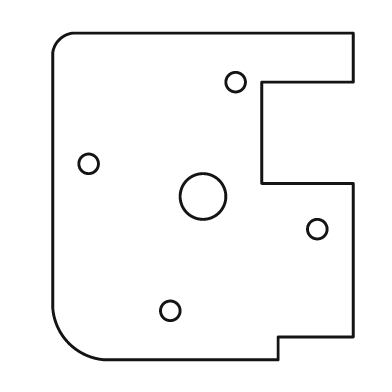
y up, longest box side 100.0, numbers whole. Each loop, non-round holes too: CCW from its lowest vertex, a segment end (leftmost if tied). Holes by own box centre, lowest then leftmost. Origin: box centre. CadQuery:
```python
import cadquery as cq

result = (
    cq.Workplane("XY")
    .moveTo(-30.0, -50.0)
    .lineTo(23.0, -50.0)
    .lineTo(23.0, -43.0)
    .lineTo(46.0, -43.0)
    .lineTo(46.0, 4.0)
    .lineTo(18.0, 4.0)
    .lineTo(18.0, 35.0)
    .lineTo(46.0, 35.0)
    .lineTo(46.0, 50.0)
    .lineTo(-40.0, 50.0)
    .threePointArc((-44.0, 48.0), (-46.0, 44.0))
    .lineTo(-46.0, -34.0)
    .threePointArc((-41.0, -45.0), (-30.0, -50.0))
    .close()
    .moveTo(-10.0, -35.0)
    .circle(3.0)
    .moveTo(35.0, -10.0)
    .circle(3.0)
    .moveTo(0.0, 0.0)
    .circle(7.0)
    .moveTo(-35.0, 10.0)
    .circle(3.0)
    .moveTo(10.0, 35.0)
    .circle(3.0)
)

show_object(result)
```